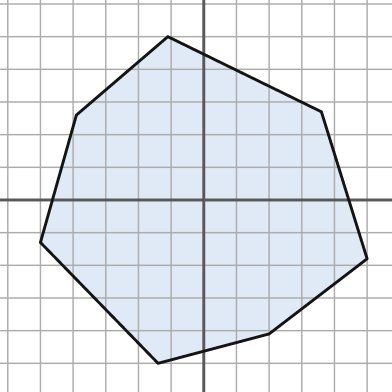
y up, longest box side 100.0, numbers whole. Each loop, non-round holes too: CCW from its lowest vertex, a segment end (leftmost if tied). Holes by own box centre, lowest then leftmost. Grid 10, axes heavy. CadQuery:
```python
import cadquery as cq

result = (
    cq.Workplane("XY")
    .moveTo(-14.0, -50.0)
    .lineTo(20.0, -41.0)
    .lineTo(50.0, -18.0)
    .lineTo(36.0, 27.0)
    .lineTo(-11.0, 50.0)
    .lineTo(-39.0, 26.0)
    .lineTo(-50.0, -13.0)
    .close()
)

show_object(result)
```